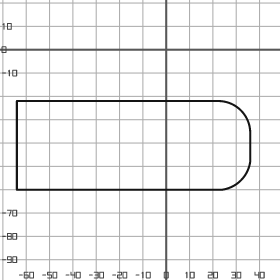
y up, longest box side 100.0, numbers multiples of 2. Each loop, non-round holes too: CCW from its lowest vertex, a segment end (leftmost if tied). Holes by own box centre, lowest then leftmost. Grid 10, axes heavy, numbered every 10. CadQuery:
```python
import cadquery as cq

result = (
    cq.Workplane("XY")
    .moveTo(-64.0, -60.0)
    .lineTo(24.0, -60.0)
    .threePointArc((32.0, -56.0), (36.0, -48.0))
    .lineTo(36.0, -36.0)
    .threePointArc((32.0, -26.0), (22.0, -22.0))
    .lineTo(-64.0, -22.0)
    .close()
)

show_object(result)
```